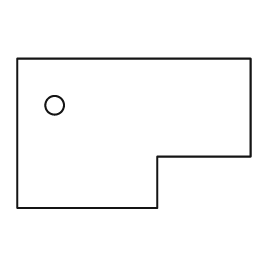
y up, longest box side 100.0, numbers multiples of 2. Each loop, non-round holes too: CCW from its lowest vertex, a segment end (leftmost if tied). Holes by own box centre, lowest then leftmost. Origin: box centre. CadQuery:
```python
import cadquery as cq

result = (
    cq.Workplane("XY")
    .moveTo(-50.0, -32.0)
    .lineTo(10.0, -32.0)
    .lineTo(10.0, -10.0)
    .lineTo(50.0, -10.0)
    .lineTo(50.0, 32.0)
    .lineTo(-50.0, 32.0)
    .close()
    .moveTo(-34.0, 12.0)
    .circle(4.0)
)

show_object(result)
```